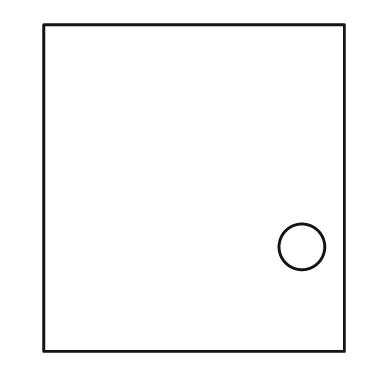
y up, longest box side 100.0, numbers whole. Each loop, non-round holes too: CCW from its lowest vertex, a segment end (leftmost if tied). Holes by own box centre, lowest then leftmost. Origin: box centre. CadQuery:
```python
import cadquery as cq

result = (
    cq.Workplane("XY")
    .moveTo(-46.0, -50.0)
    .lineTo(46.0, -50.0)
    .lineTo(46.0, 50.0)
    .lineTo(-46.0, 50.0)
    .close()
    .moveTo(33.0, -18.0)
    .circle(7.0)
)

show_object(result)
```